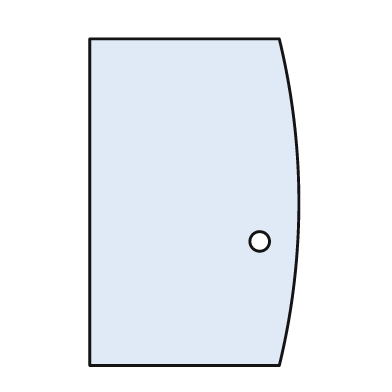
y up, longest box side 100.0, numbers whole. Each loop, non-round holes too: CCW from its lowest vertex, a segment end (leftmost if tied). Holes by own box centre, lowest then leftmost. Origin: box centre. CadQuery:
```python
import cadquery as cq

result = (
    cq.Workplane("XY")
    .moveTo(-32.0, -50.0)
    .lineTo(26.0, -50.0)
    .threePointArc((32.0, 0.0), (26.0, 50.0))
    .lineTo(-32.0, 50.0)
    .close()
    .moveTo(20.0, -12.0)
    .circle(3.0)
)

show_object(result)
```